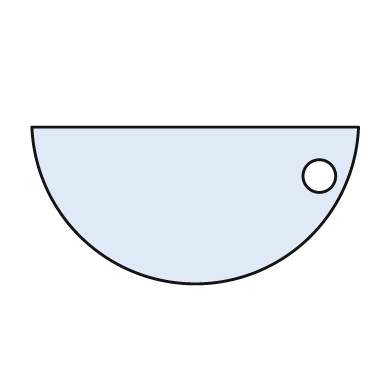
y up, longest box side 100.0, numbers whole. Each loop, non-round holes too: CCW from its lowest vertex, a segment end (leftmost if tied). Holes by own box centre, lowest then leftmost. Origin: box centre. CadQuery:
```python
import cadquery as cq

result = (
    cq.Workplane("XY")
    .moveTo(-50.0, 24.0)
    .threePointArc((0.0, -24.0), (50.0, 24.0))
    .close()
    .moveTo(38.0, 9.0)
    .circle(5.0)
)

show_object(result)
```